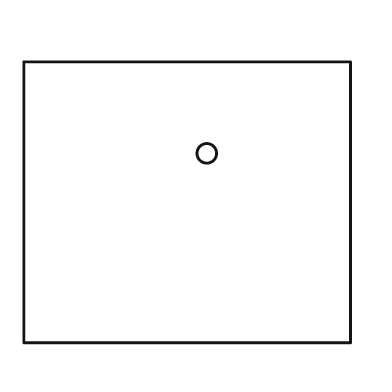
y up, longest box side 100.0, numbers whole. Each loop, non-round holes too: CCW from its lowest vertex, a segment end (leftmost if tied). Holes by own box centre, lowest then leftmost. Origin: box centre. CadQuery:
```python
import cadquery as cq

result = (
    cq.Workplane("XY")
    .moveTo(-50.0, -43.0)
    .lineTo(50.0, -43.0)
    .lineTo(50.0, 43.0)
    .lineTo(-50.0, 43.0)
    .close()
    .moveTo(6.0, 15.0)
    .circle(3.0)
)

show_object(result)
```